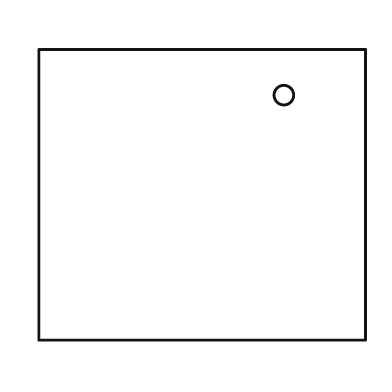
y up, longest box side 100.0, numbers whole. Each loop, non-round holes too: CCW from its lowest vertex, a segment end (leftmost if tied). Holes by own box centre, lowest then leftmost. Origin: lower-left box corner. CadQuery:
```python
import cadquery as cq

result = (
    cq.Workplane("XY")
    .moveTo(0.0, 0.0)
    .lineTo(100.0, 0.0)
    .lineTo(100.0, 89.0)
    .lineTo(0.0, 89.0)
    .close()
    .moveTo(75.0, 75.0)
    .circle(3.0)
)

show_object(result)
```